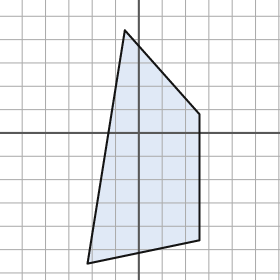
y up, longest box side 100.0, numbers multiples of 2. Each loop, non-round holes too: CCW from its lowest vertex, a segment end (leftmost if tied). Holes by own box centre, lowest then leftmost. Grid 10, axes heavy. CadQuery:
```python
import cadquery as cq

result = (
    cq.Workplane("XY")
    .moveTo(-22.0, -56.0)
    .lineTo(26.0, -46.0)
    .lineTo(26.0, 8.0)
    .lineTo(-6.0, 44.0)
    .close()
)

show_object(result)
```